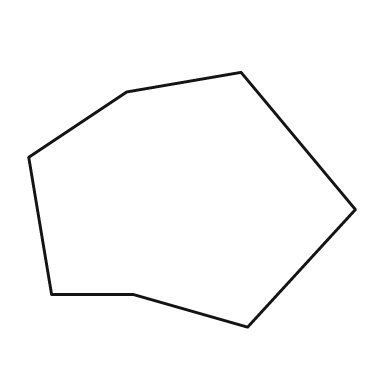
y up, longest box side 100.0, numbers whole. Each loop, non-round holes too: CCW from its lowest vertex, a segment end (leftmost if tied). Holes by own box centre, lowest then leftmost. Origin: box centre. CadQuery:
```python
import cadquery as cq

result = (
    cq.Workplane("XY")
    .moveTo(17.0, -39.0)
    .lineTo(50.0, -3.0)
    .lineTo(15.0, 39.0)
    .lineTo(-20.0, 33.0)
    .lineTo(-50.0, 13.0)
    .lineTo(-43.0, -29.0)
    .lineTo(-18.0, -29.0)
    .close()
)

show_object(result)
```